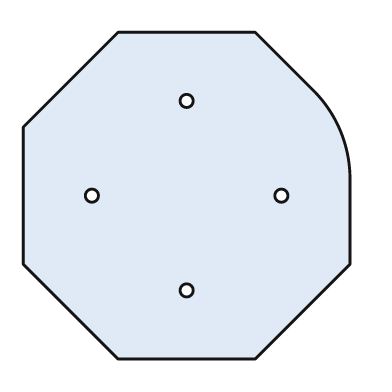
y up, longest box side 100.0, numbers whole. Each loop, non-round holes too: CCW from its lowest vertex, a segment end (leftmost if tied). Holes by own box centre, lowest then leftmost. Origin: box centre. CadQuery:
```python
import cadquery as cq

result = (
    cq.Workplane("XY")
    .moveTo(-21.0, -50.0)
    .lineTo(21.0, -50.0)
    .lineTo(50.0, -21.0)
    .lineTo(50.0, 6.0)
    .threePointArc((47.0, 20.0), (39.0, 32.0))
    .lineTo(21.0, 50.0)
    .lineTo(-21.0, 50.0)
    .lineTo(-50.0, 21.0)
    .lineTo(-50.0, -21.0)
    .close()
    .moveTo(0.0, -29.0)
    .circle(2.0)
    .moveTo(-29.0, 0.0)
    .circle(2.0)
    .moveTo(29.0, 0.0)
    .circle(2.0)
    .moveTo(0.0, 29.0)
    .circle(2.0)
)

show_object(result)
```